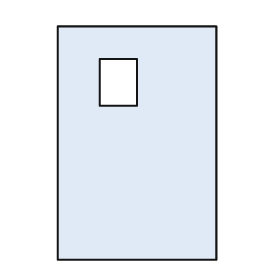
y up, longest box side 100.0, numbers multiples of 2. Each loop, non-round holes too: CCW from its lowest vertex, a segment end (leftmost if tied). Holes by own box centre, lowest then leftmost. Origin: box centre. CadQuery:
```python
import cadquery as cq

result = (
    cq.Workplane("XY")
    .moveTo(-34.0, -50.0)
    .lineTo(34.0, -50.0)
    .lineTo(34.0, 50.0)
    .lineTo(-34.0, 50.0)
    .close()
    .moveTo(-16.0, 16.0)
    .lineTo(0.0, 16.0)
    .lineTo(0.0, 36.0)
    .lineTo(-16.0, 36.0)
    .close()
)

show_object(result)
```